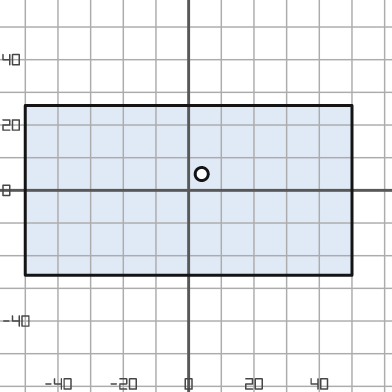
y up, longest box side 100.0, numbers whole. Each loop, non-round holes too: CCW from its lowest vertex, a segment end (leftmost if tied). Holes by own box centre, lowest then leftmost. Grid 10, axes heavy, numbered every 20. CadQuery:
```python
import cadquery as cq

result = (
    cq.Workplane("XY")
    .moveTo(-50.0, -26.0)
    .lineTo(50.0, -26.0)
    .lineTo(50.0, 26.0)
    .lineTo(-50.0, 26.0)
    .close()
    .moveTo(4.0, 5.0)
    .circle(2.0)
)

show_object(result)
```